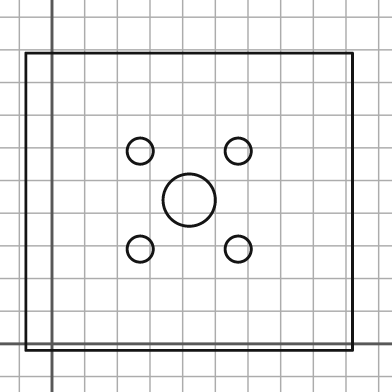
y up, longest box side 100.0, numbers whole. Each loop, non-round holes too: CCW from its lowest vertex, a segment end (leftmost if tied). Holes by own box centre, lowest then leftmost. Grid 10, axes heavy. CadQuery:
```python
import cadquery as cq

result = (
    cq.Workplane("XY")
    .moveTo(-8.0, -2.0)
    .lineTo(92.0, -2.0)
    .lineTo(92.0, 89.0)
    .lineTo(-8.0, 89.0)
    .close()
    .moveTo(27.0, 29.0)
    .circle(4.0)
    .moveTo(57.0, 29.0)
    .circle(4.0)
    .moveTo(42.0, 44.0)
    .circle(8.0)
    .moveTo(27.0, 59.0)
    .circle(4.0)
    .moveTo(57.0, 59.0)
    .circle(4.0)
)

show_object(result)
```